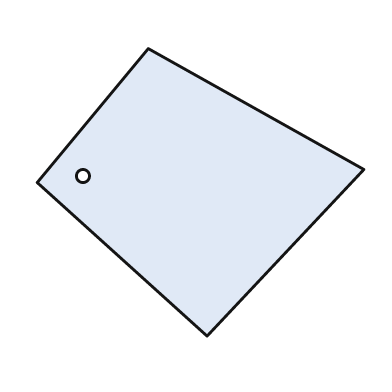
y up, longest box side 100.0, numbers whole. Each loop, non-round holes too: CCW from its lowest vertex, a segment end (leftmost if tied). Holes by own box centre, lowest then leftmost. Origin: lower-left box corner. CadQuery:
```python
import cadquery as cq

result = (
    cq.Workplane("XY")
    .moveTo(52.0, 0.0)
    .lineTo(100.0, 51.0)
    .lineTo(34.0, 88.0)
    .lineTo(0.0, 47.0)
    .close()
    .moveTo(14.0, 49.0)
    .circle(2.0)
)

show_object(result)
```